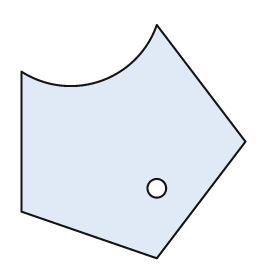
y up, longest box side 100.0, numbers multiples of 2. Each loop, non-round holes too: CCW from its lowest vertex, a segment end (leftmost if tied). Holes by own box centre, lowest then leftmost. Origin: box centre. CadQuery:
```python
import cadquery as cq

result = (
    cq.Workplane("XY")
    .moveTo(10.0, -50.0)
    .lineTo(48.0, 0.0)
    .lineTo(10.0, 50.0)
    .threePointArc((-14.0, 26.0), (-48.0, 30.0))
    .lineTo(-48.0, -30.0)
    .close()
    .moveTo(10.0, -20.0)
    .circle(4.0)
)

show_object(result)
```